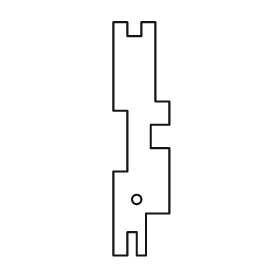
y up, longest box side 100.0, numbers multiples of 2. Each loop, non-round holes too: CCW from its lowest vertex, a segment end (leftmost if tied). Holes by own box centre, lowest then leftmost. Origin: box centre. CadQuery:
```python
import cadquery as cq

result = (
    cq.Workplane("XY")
    .moveTo(-12.0, -50.0)
    .lineTo(-6.0, -50.0)
    .lineTo(-6.0, -40.0)
    .lineTo(-2.0, -40.0)
    .lineTo(-2.0, -50.0)
    .lineTo(2.0, -50.0)
    .lineTo(2.0, -32.0)
    .lineTo(12.0, -32.0)
    .lineTo(12.0, -4.0)
    .lineTo(4.0, -4.0)
    .lineTo(4.0, 6.0)
    .lineTo(12.0, 6.0)
    .lineTo(12.0, 16.0)
    .lineTo(6.0, 16.0)
    .lineTo(6.0, 50.0)
    .lineTo(0.0, 50.0)
    .lineTo(0.0, 44.0)
    .lineTo(-6.0, 44.0)
    .lineTo(-6.0, 50.0)
    .lineTo(-12.0, 50.0)
    .lineTo(-12.0, 12.0)
    .lineTo(-6.0, 12.0)
    .lineTo(-6.0, -14.0)
    .lineTo(-12.0, -14.0)
    .close()
    .moveTo(-2.0, -26.0)
    .circle(2.0)
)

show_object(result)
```